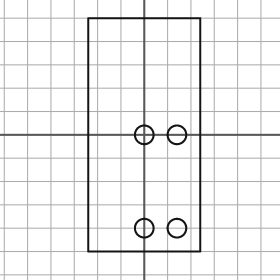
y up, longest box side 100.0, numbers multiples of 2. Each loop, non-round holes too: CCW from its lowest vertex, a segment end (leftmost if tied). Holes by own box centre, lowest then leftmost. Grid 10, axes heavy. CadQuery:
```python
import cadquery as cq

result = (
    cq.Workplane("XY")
    .moveTo(-24.0, -50.0)
    .lineTo(24.0, -50.0)
    .lineTo(24.0, 50.0)
    .lineTo(-24.0, 50.0)
    .close()
    .moveTo(0.0, -40.0)
    .circle(4.0)
    .moveTo(14.0, -40.0)
    .circle(4.0)
    .moveTo(0.0, 0.0)
    .circle(4.0)
    .moveTo(14.0, 0.0)
    .circle(4.0)
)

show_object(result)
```